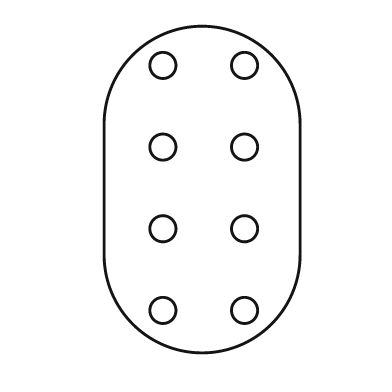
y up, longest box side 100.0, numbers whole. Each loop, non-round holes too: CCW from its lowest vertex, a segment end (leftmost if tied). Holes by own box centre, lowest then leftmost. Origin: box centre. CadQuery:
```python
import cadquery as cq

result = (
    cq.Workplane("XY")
    .moveTo(-30.0, -20.0)
    .threePointArc((0.0, -50.0), (30.0, -20.0))
    .lineTo(30.0, 20.0)
    .threePointArc((0.0, 50.0), (-30.0, 20.0))
    .close()
    .moveTo(-12.0, -37.0)
    .circle(4.0)
    .moveTo(13.0, -37.0)
    .circle(4.0)
    .moveTo(-12.0, -12.0)
    .circle(4.0)
    .moveTo(13.0, -12.0)
    .circle(4.0)
    .moveTo(-12.0, 13.0)
    .circle(4.0)
    .moveTo(13.0, 13.0)
    .circle(4.0)
    .moveTo(-12.0, 38.0)
    .circle(4.0)
    .moveTo(13.0, 38.0)
    .circle(4.0)
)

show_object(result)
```